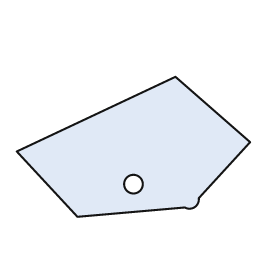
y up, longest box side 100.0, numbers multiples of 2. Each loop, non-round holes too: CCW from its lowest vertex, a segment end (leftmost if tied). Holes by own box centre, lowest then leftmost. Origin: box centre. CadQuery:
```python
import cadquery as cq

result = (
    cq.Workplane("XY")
    .moveTo(-24.0, -30.0)
    .lineTo(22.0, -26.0)
    .threePointArc((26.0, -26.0), (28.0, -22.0))
    .lineTo(50.0, 2.0)
    .lineTo(18.0, 30.0)
    .lineTo(-50.0, -2.0)
    .close()
    .moveTo(0.0, -16.0)
    .circle(4.0)
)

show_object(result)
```